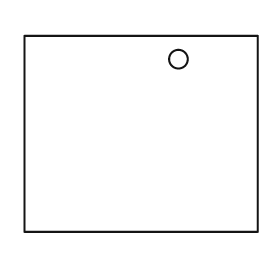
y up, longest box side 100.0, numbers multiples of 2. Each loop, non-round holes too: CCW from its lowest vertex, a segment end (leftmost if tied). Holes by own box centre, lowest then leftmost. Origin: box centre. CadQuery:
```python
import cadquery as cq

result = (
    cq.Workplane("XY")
    .moveTo(-50.0, -42.0)
    .lineTo(50.0, -42.0)
    .lineTo(50.0, 42.0)
    .lineTo(-50.0, 42.0)
    .close()
    .moveTo(16.0, 32.0)
    .circle(4.0)
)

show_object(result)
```